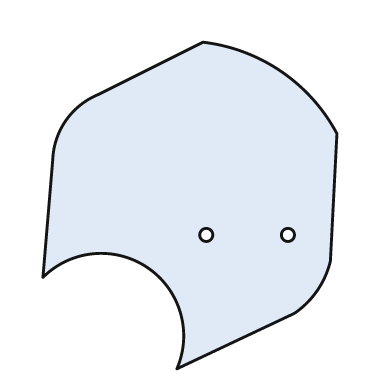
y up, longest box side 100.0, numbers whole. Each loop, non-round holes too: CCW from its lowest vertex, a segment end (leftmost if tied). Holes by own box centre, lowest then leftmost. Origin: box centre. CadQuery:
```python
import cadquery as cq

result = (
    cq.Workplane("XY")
    .moveTo(-4.0, -50.0)
    .lineTo(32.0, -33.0)
    .threePointArc((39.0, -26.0), (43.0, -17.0))
    .lineTo(45.0, 22.0)
    .threePointArc((28.0, 41.0), (4.0, 50.0))
    .lineTo(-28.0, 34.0)
    .threePointArc((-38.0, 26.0), (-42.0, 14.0))
    .lineTo(-45.0, -22.0)
    .threePointArc((-13.0, -19.0), (-4.0, -50.0))
    .close()
    .moveTo(5.0, -9.0)
    .circle(2.0)
    .moveTo(30.0, -9.0)
    .circle(2.0)
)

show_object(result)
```